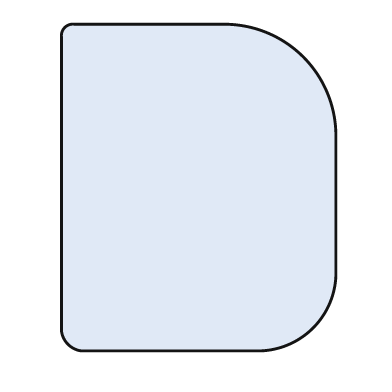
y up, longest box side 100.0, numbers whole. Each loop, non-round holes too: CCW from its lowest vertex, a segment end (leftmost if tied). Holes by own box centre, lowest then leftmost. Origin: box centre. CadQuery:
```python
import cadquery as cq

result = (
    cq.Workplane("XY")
    .moveTo(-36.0, -50.0)
    .lineTo(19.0, -50.0)
    .threePointArc((35.0, -43.0), (42.0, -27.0))
    .lineTo(42.0, 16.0)
    .threePointArc((32.0, 40.0), (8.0, 50.0))
    .lineTo(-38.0, 50.0)
    .threePointArc((-41.0, 49.0), (-42.0, 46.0))
    .lineTo(-42.0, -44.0)
    .threePointArc((-40.0, -48.0), (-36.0, -50.0))
    .close()
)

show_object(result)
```